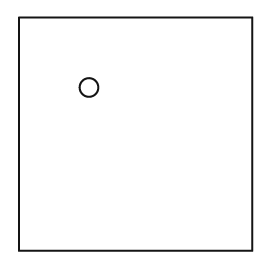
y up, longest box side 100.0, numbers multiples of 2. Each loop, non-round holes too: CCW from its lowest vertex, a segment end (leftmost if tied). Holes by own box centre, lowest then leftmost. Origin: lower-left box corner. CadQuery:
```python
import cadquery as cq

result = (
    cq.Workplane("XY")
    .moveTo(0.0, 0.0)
    .lineTo(100.0, 0.0)
    .lineTo(100.0, 100.0)
    .lineTo(0.0, 100.0)
    .close()
    .moveTo(30.0, 70.0)
    .circle(4.0)
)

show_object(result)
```